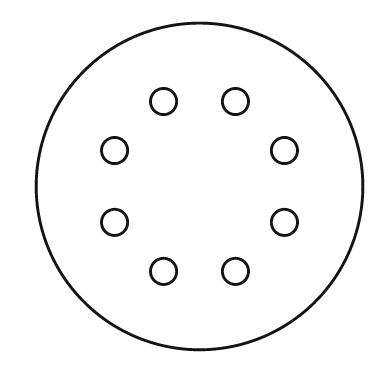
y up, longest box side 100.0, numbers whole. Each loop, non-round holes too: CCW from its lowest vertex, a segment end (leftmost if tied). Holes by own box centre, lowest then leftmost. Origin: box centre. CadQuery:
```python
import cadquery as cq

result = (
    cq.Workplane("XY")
    .moveTo(0.0, 0.0)
    .circle(50.0)
    .moveTo(-11.0, -26.0)
    .circle(4.0)
    .moveTo(11.0, -26.0)
    .circle(4.0)
    .moveTo(-26.0, -11.0)
    .circle(4.0)
    .moveTo(26.0, -11.0)
    .circle(4.0)
    .moveTo(-26.0, 11.0)
    .circle(4.0)
    .moveTo(26.0, 11.0)
    .circle(4.0)
    .moveTo(-11.0, 26.0)
    .circle(4.0)
    .moveTo(11.0, 26.0)
    .circle(4.0)
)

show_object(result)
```